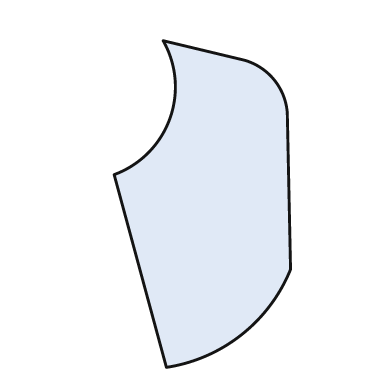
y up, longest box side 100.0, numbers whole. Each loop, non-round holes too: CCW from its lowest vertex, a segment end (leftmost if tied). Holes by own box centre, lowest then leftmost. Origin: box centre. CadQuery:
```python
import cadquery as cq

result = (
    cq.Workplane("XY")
    .moveTo(-11.0, -50.0)
    .threePointArc((12.0, -40.0), (27.0, -20.0))
    .lineTo(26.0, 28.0)
    .threePointArc((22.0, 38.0), (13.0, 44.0))
    .lineTo(-12.0, 50.0)
    .threePointArc((-10.0, 26.0), (-27.0, 9.0))
    .close()
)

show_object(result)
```